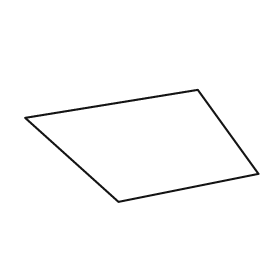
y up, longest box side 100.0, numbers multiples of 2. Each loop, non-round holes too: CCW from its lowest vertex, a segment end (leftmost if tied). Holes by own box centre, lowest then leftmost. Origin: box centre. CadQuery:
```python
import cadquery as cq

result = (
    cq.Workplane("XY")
    .moveTo(-10.0, -24.0)
    .lineTo(50.0, -12.0)
    .lineTo(24.0, 24.0)
    .lineTo(-50.0, 12.0)
    .close()
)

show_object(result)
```